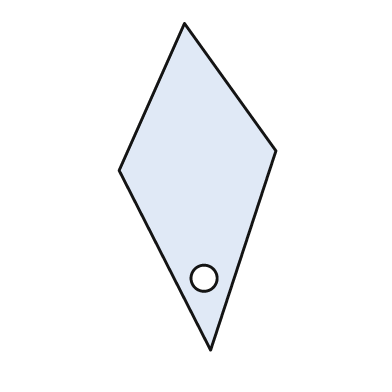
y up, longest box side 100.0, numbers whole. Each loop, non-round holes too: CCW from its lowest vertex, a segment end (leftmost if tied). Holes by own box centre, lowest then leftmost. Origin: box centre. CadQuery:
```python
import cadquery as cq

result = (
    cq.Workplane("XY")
    .moveTo(4.0, -50.0)
    .lineTo(24.0, 11.0)
    .lineTo(-4.0, 50.0)
    .lineTo(-24.0, 5.0)
    .close()
    .moveTo(2.0, -28.0)
    .circle(4.0)
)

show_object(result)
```